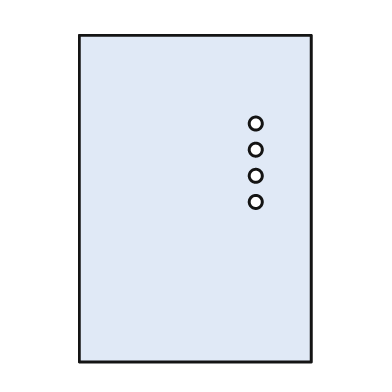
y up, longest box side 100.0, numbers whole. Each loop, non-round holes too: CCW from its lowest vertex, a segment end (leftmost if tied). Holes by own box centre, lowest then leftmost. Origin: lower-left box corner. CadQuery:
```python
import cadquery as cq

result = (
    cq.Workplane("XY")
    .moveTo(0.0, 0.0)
    .lineTo(71.0, 0.0)
    .lineTo(71.0, 100.0)
    .lineTo(0.0, 100.0)
    .close()
    .moveTo(54.0, 49.0)
    .circle(2.0)
    .moveTo(54.0, 57.0)
    .circle(2.0)
    .moveTo(54.0, 65.0)
    .circle(2.0)
    .moveTo(54.0, 73.0)
    .circle(2.0)
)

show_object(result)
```